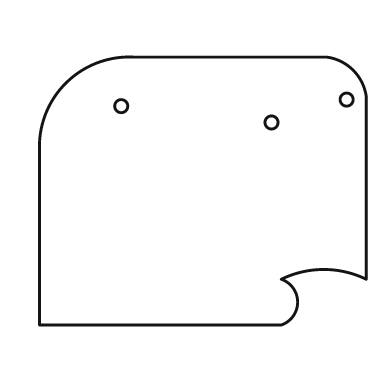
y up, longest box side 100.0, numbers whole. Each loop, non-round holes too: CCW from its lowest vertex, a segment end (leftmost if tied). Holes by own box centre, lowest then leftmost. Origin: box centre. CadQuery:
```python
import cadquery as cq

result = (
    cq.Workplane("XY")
    .moveTo(-50.0, -41.0)
    .lineTo(24.0, -41.0)
    .threePointArc((29.0, -34.0), (24.0, -27.0))
    .threePointArc((37.0, -24.0), (50.0, -27.0))
    .lineTo(50.0, 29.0)
    .threePointArc((46.0, 37.0), (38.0, 41.0))
    .lineTo(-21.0, 41.0)
    .threePointArc((-42.0, 33.0), (-50.0, 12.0))
    .close()
    .moveTo(21.0, 21.0)
    .circle(2.0)
    .moveTo(-25.0, 26.0)
    .circle(2.0)
    .moveTo(44.0, 28.0)
    .circle(2.0)
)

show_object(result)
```